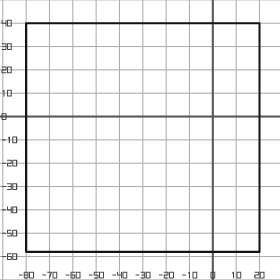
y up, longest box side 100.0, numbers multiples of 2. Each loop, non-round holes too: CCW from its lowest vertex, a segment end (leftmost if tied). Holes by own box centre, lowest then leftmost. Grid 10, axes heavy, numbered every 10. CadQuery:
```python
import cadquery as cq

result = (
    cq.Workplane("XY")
    .moveTo(-80.0, -58.0)
    .lineTo(20.0, -58.0)
    .lineTo(20.0, 40.0)
    .lineTo(-80.0, 40.0)
    .close()
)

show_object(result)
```